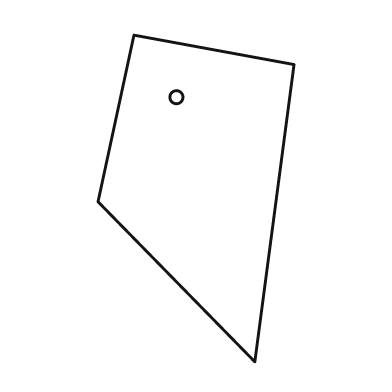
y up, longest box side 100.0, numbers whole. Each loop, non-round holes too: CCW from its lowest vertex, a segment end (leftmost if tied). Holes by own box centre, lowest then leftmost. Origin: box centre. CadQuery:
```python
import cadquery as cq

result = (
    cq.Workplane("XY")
    .moveTo(18.0, -50.0)
    .lineTo(30.0, 41.0)
    .lineTo(-19.0, 50.0)
    .lineTo(-30.0, -1.0)
    .close()
    .moveTo(-6.0, 31.0)
    .circle(2.0)
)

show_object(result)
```